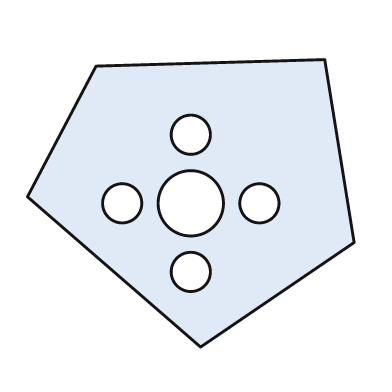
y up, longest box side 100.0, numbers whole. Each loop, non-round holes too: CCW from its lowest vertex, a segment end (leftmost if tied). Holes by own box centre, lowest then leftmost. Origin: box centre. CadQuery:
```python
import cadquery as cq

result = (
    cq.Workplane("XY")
    .moveTo(3.0, -44.0)
    .lineTo(50.0, -12.0)
    .lineTo(41.0, 44.0)
    .lineTo(-29.0, 42.0)
    .lineTo(-50.0, 2.0)
    .close()
    .moveTo(0.0, -21.0)
    .circle(6.0)
    .moveTo(-21.0, 0.0)
    .circle(6.0)
    .moveTo(0.0, 0.0)
    .circle(10.0)
    .moveTo(21.0, 0.0)
    .circle(6.0)
    .moveTo(0.0, 21.0)
    .circle(6.0)
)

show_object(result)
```